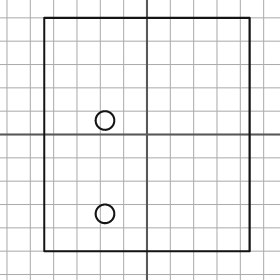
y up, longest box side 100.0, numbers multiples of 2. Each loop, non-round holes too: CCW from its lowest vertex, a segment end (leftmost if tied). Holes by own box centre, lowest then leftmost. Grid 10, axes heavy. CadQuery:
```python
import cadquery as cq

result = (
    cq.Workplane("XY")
    .moveTo(-44.0, -50.0)
    .lineTo(44.0, -50.0)
    .lineTo(44.0, 50.0)
    .lineTo(-44.0, 50.0)
    .close()
    .moveTo(-18.0, -34.0)
    .circle(4.0)
    .moveTo(-18.0, 6.0)
    .circle(4.0)
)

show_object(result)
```